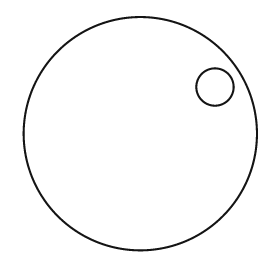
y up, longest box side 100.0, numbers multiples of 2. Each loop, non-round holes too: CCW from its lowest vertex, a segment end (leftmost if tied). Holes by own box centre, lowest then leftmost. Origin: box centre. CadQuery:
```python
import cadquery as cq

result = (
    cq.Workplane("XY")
    .moveTo(0.0, 0.0)
    .circle(50.0)
    .moveTo(32.0, 20.0)
    .circle(8.0)
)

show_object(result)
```